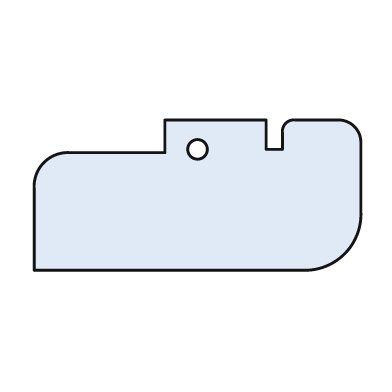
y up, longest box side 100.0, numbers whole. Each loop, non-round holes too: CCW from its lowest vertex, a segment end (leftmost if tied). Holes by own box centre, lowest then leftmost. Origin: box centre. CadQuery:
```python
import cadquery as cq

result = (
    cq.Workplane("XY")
    .moveTo(-50.0, -23.0)
    .lineTo(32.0, -23.0)
    .threePointArc((45.0, -18.0), (50.0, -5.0))
    .lineTo(50.0, 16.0)
    .threePointArc((48.0, 21.0), (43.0, 23.0))
    .lineTo(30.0, 23.0)
    .threePointArc((27.0, 22.0), (26.0, 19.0))
    .lineTo(26.0, 14.0)
    .lineTo(21.0, 14.0)
    .lineTo(21.0, 23.0)
    .lineTo(-10.0, 23.0)
    .lineTo(-10.0, 13.0)
    .lineTo(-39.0, 13.0)
    .threePointArc((-47.0, 10.0), (-50.0, 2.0))
    .close()
    .moveTo(0.0, 14.0)
    .circle(3.0)
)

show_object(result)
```